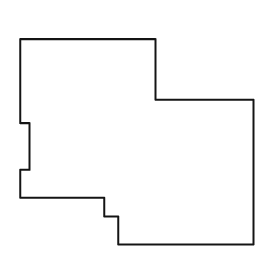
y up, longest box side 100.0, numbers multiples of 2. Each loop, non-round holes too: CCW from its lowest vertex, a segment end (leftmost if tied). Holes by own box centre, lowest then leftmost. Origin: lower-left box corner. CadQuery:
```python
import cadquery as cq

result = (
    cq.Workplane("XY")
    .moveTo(42.0, 0.0)
    .lineTo(100.0, 0.0)
    .lineTo(100.0, 62.0)
    .lineTo(58.0, 62.0)
    .lineTo(58.0, 88.0)
    .lineTo(0.0, 88.0)
    .lineTo(0.0, 52.0)
    .lineTo(4.0, 52.0)
    .lineTo(4.0, 32.0)
    .lineTo(0.0, 32.0)
    .lineTo(0.0, 20.0)
    .lineTo(36.0, 20.0)
    .lineTo(36.0, 12.0)
    .lineTo(42.0, 12.0)
    .close()
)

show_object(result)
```